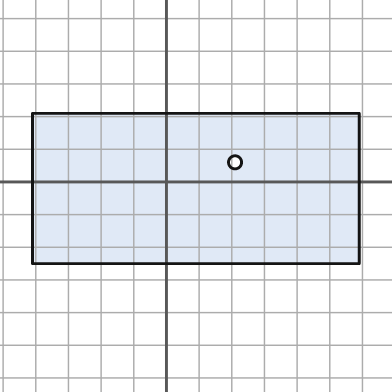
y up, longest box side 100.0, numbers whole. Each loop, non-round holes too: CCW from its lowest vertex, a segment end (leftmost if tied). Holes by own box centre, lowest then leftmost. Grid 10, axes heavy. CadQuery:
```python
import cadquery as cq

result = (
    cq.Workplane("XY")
    .moveTo(-41.0, -25.0)
    .lineTo(59.0, -25.0)
    .lineTo(59.0, 21.0)
    .lineTo(-41.0, 21.0)
    .close()
    .moveTo(21.0, 6.0)
    .circle(2.0)
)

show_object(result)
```